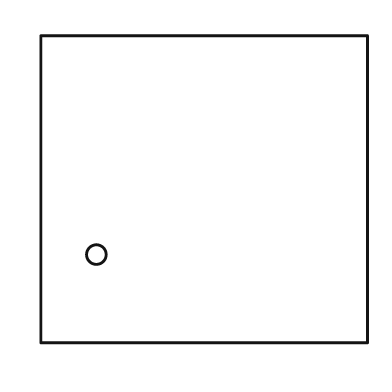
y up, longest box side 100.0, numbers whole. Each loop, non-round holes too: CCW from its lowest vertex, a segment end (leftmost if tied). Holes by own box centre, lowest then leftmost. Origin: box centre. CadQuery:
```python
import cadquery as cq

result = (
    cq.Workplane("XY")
    .moveTo(-50.0, -47.0)
    .lineTo(50.0, -47.0)
    .lineTo(50.0, 47.0)
    .lineTo(-50.0, 47.0)
    .close()
    .moveTo(-33.0, -20.0)
    .circle(3.0)
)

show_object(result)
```